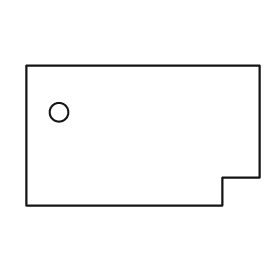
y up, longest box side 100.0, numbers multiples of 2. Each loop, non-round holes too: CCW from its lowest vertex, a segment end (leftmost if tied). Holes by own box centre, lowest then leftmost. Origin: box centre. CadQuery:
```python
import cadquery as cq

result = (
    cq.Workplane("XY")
    .moveTo(-50.0, -30.0)
    .lineTo(34.0, -30.0)
    .lineTo(34.0, -18.0)
    .lineTo(50.0, -18.0)
    .lineTo(50.0, 30.0)
    .lineTo(-50.0, 30.0)
    .close()
    .moveTo(-36.0, 10.0)
    .circle(4.0)
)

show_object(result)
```